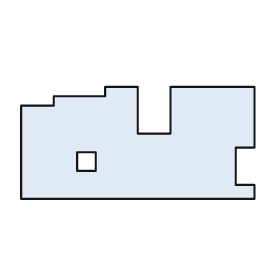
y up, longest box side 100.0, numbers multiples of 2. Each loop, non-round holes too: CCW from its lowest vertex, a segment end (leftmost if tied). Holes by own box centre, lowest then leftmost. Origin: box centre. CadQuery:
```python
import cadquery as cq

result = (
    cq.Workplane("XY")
    .moveTo(-50.0, -24.0)
    .lineTo(50.0, -24.0)
    .lineTo(50.0, -18.0)
    .lineTo(42.0, -18.0)
    .lineTo(42.0, -2.0)
    .lineTo(50.0, -2.0)
    .lineTo(50.0, 24.0)
    .lineTo(14.0, 24.0)
    .lineTo(14.0, 4.0)
    .lineTo(0.0, 4.0)
    .lineTo(0.0, 24.0)
    .lineTo(-14.0, 24.0)
    .lineTo(-14.0, 20.0)
    .lineTo(-36.0, 20.0)
    .lineTo(-36.0, 16.0)
    .lineTo(-50.0, 16.0)
    .close()
    .moveTo(-26.0, -12.0)
    .lineTo(-18.0, -12.0)
    .lineTo(-18.0, -4.0)
    .lineTo(-26.0, -4.0)
    .close()
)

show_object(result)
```